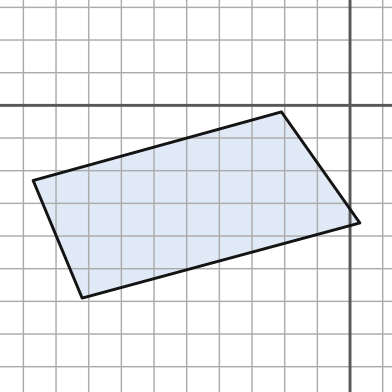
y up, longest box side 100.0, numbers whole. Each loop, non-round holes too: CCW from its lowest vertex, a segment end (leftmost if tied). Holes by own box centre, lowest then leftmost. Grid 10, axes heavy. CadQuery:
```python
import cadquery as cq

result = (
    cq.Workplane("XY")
    .moveTo(-82.0, -59.0)
    .lineTo(3.0, -36.0)
    .lineTo(-21.0, -2.0)
    .lineTo(-97.0, -23.0)
    .close()
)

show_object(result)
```